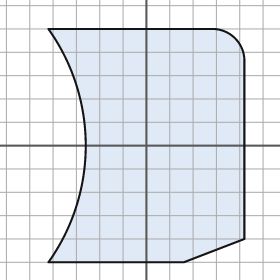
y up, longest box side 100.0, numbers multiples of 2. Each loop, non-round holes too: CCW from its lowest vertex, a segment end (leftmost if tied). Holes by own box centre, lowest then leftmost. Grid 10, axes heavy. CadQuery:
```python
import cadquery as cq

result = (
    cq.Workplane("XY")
    .moveTo(-42.0, -50.0)
    .lineTo(16.0, -50.0)
    .lineTo(42.0, -40.0)
    .lineTo(42.0, 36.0)
    .threePointArc((38.0, 46.0), (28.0, 50.0))
    .lineTo(-42.0, 50.0)
    .threePointArc((-26.0, 0.0), (-42.0, -50.0))
    .close()
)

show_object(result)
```